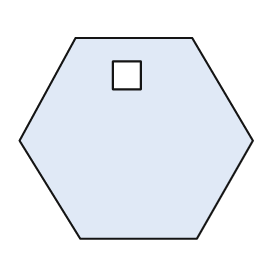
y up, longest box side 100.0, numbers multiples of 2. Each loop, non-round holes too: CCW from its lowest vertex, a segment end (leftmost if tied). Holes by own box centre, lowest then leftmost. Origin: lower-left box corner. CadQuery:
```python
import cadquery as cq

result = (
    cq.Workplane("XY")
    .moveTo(26.0, 0.0)
    .lineTo(76.0, 0.0)
    .lineTo(100.0, 42.0)
    .lineTo(74.0, 86.0)
    .lineTo(24.0, 86.0)
    .lineTo(0.0, 42.0)
    .close()
    .moveTo(40.0, 64.0)
    .lineTo(52.0, 64.0)
    .lineTo(52.0, 76.0)
    .lineTo(40.0, 76.0)
    .close()
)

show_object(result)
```